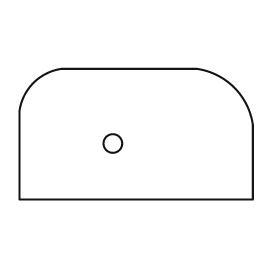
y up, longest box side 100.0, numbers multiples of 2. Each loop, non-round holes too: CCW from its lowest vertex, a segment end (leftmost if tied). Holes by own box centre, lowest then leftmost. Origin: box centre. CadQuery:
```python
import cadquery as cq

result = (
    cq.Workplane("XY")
    .moveTo(-50.0, -28.0)
    .lineTo(50.0, -28.0)
    .lineTo(50.0, 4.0)
    .threePointArc((42.0, 20.0), (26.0, 28.0))
    .lineTo(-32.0, 28.0)
    .threePointArc((-44.0, 22.0), (-50.0, 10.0))
    .close()
    .moveTo(-10.0, -4.0)
    .circle(4.0)
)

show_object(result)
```